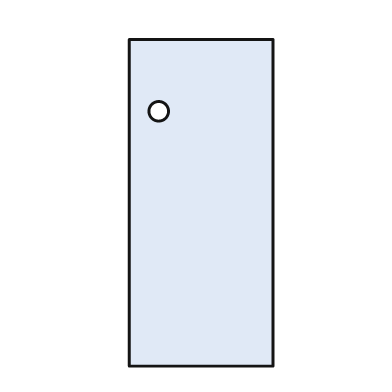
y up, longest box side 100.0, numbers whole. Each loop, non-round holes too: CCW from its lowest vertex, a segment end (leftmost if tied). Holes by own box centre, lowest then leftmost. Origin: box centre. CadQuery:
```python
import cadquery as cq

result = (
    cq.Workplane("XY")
    .moveTo(-22.0, -50.0)
    .lineTo(22.0, -50.0)
    .lineTo(22.0, 50.0)
    .lineTo(-22.0, 50.0)
    .close()
    .moveTo(-13.0, 28.0)
    .circle(3.0)
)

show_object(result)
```